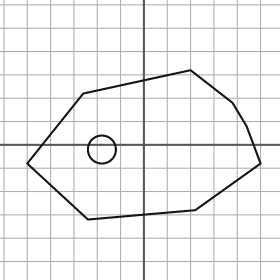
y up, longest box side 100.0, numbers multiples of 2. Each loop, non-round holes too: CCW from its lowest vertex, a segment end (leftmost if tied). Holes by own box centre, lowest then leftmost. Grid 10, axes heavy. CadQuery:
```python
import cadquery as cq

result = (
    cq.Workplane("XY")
    .moveTo(-24.0, -32.0)
    .lineTo(22.0, -28.0)
    .lineTo(50.0, -8.0)
    .lineTo(44.0, 8.0)
    .lineTo(38.0, 18.0)
    .lineTo(20.0, 32.0)
    .lineTo(-26.0, 22.0)
    .lineTo(-50.0, -8.0)
    .close()
    .moveTo(-18.0, -2.0)
    .circle(6.0)
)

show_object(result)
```